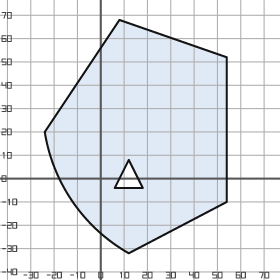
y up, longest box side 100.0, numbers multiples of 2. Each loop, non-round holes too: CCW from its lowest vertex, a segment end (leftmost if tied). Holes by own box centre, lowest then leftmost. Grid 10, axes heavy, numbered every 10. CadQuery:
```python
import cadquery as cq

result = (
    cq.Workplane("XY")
    .moveTo(12.0, -32.0)
    .lineTo(54.0, -10.0)
    .lineTo(54.0, 52.0)
    .lineTo(8.0, 68.0)
    .lineTo(-24.0, 20.0)
    .threePointArc((-12.0, -10.0), (12.0, -32.0))
    .close()
    .moveTo(6.0, -4.0)
    .lineTo(18.0, -4.0)
    .lineTo(12.0, 8.0)
    .close()
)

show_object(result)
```